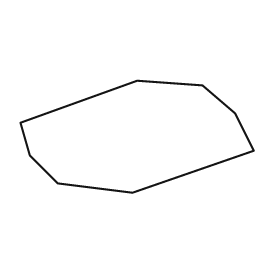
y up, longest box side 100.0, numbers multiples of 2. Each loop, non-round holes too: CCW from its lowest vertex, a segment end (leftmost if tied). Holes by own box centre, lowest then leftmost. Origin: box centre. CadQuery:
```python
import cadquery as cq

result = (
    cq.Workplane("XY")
    .moveTo(-2.0, -24.0)
    .lineTo(50.0, -6.0)
    .lineTo(42.0, 10.0)
    .lineTo(28.0, 22.0)
    .lineTo(0.0, 24.0)
    .lineTo(-50.0, 6.0)
    .lineTo(-46.0, -8.0)
    .lineTo(-34.0, -20.0)
    .close()
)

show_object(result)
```